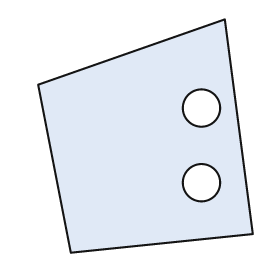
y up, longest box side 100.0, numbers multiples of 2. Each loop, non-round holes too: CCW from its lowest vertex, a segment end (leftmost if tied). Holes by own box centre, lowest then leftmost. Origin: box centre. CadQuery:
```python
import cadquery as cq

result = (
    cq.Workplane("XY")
    .moveTo(-32.0, -50.0)
    .lineTo(46.0, -42.0)
    .lineTo(34.0, 50.0)
    .lineTo(-46.0, 22.0)
    .close()
    .moveTo(24.0, -20.0)
    .circle(8.0)
    .moveTo(24.0, 12.0)
    .circle(8.0)
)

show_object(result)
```